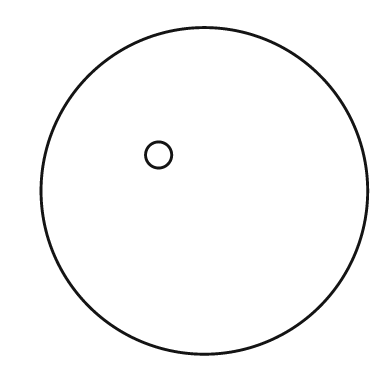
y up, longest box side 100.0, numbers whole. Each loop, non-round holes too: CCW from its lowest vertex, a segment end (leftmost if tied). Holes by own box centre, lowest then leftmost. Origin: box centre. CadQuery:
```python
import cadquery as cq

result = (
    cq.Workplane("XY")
    .moveTo(0.0, 0.0)
    .circle(50.0)
    .moveTo(-14.0, 11.0)
    .circle(4.0)
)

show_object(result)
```